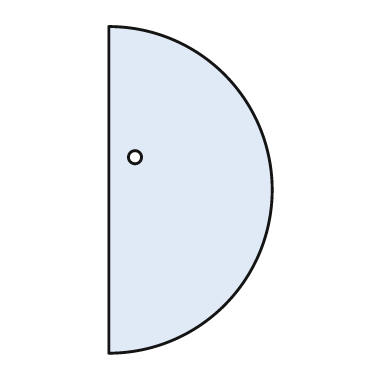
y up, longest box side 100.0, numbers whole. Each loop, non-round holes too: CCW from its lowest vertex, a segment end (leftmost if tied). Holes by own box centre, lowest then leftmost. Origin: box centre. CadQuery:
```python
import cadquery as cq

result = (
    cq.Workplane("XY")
    .moveTo(-25.0, -50.0)
    .threePointArc((25.0, 0.0), (-25.0, 50.0))
    .close()
    .moveTo(-17.0, 10.0)
    .circle(2.0)
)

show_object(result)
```